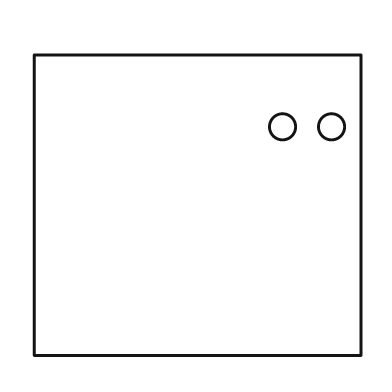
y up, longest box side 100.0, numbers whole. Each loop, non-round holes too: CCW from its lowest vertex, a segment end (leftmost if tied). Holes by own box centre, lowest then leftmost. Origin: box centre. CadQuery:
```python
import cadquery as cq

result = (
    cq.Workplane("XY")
    .moveTo(-50.0, -46.0)
    .lineTo(50.0, -46.0)
    .lineTo(50.0, 46.0)
    .lineTo(-50.0, 46.0)
    .close()
    .moveTo(26.0, 24.0)
    .circle(4.0)
    .moveTo(41.0, 24.0)
    .circle(4.0)
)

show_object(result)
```